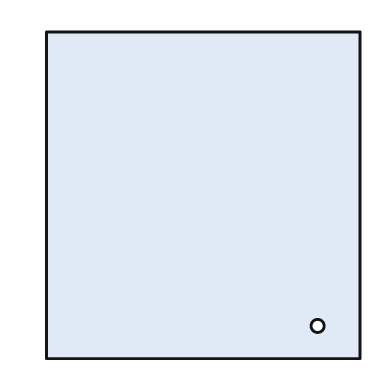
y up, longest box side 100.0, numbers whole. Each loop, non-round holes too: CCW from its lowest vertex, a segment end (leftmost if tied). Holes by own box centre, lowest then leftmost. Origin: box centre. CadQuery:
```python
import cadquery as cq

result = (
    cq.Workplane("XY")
    .moveTo(-48.0, -50.0)
    .lineTo(48.0, -50.0)
    .lineTo(48.0, 50.0)
    .lineTo(-48.0, 50.0)
    .close()
    .moveTo(35.0, -40.0)
    .circle(2.0)
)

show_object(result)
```